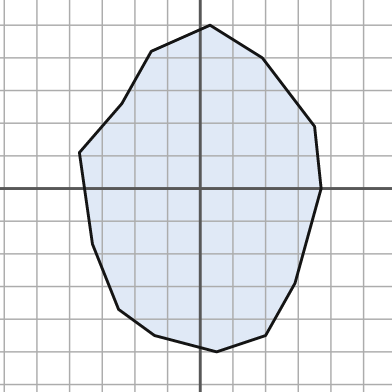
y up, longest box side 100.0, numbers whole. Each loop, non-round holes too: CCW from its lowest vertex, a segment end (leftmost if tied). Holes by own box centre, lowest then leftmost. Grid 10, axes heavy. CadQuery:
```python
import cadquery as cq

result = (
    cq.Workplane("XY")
    .moveTo(5.0, -50.0)
    .lineTo(20.0, -45.0)
    .lineTo(29.0, -29.0)
    .lineTo(37.0, 0.0)
    .lineTo(35.0, 19.0)
    .lineTo(19.0, 40.0)
    .lineTo(3.0, 50.0)
    .lineTo(-15.0, 42.0)
    .lineTo(-24.0, 26.0)
    .lineTo(-37.0, 11.0)
    .lineTo(-33.0, -17.0)
    .lineTo(-25.0, -37.0)
    .lineTo(-14.0, -45.0)
    .close()
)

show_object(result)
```